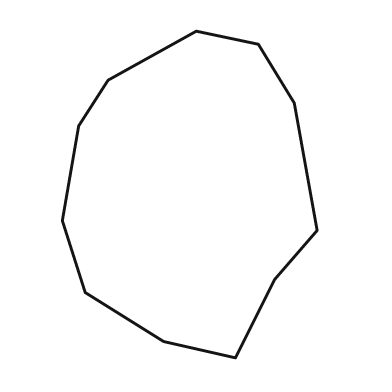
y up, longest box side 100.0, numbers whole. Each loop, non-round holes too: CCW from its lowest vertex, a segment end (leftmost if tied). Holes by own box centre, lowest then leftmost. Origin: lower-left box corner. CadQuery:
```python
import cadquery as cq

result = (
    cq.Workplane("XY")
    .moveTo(53.0, 0.0)
    .lineTo(65.0, 24.0)
    .lineTo(78.0, 39.0)
    .lineTo(71.0, 78.0)
    .lineTo(60.0, 96.0)
    .lineTo(41.0, 100.0)
    .lineTo(14.0, 85.0)
    .lineTo(5.0, 71.0)
    .lineTo(0.0, 42.0)
    .lineTo(7.0, 20.0)
    .lineTo(31.0, 5.0)
    .close()
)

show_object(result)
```